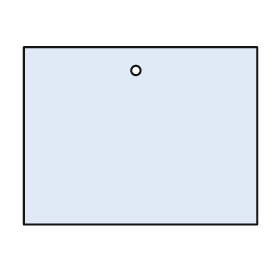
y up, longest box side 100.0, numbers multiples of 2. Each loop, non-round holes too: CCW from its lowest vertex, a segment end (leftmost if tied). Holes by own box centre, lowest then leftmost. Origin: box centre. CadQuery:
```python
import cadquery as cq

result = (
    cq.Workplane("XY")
    .moveTo(-50.0, -38.0)
    .lineTo(50.0, -38.0)
    .lineTo(50.0, 38.0)
    .lineTo(-50.0, 38.0)
    .close()
    .moveTo(-2.0, 28.0)
    .circle(2.0)
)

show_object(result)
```